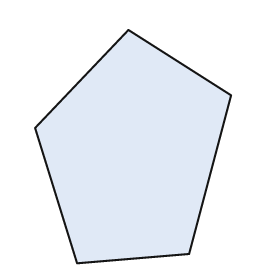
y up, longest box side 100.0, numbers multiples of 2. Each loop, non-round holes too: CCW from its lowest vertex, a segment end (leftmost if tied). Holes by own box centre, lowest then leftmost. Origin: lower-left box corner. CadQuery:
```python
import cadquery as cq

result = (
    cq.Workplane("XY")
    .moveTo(18.0, 0.0)
    .lineTo(66.0, 4.0)
    .lineTo(84.0, 72.0)
    .lineTo(40.0, 100.0)
    .lineTo(0.0, 58.0)
    .close()
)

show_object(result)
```